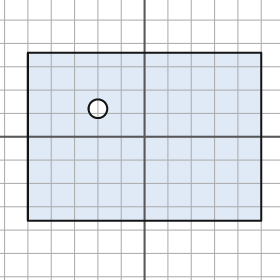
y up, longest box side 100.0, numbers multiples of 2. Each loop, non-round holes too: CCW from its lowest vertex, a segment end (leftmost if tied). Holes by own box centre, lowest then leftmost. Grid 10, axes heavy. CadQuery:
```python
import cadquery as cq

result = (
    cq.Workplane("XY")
    .moveTo(-50.0, -36.0)
    .lineTo(50.0, -36.0)
    .lineTo(50.0, 36.0)
    .lineTo(-50.0, 36.0)
    .close()
    .moveTo(-20.0, 12.0)
    .circle(4.0)
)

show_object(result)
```